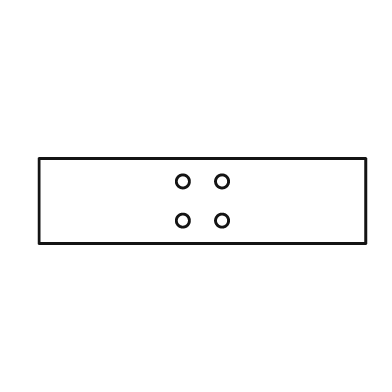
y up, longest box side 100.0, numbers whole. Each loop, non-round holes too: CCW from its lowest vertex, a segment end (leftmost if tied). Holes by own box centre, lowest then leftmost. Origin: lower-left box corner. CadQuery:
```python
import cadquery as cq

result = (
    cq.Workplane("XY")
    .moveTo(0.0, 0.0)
    .lineTo(100.0, 0.0)
    .lineTo(100.0, 26.0)
    .lineTo(0.0, 26.0)
    .close()
    .moveTo(44.0, 7.0)
    .circle(2.0)
    .moveTo(56.0, 7.0)
    .circle(2.0)
    .moveTo(44.0, 19.0)
    .circle(2.0)
    .moveTo(56.0, 19.0)
    .circle(2.0)
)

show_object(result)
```